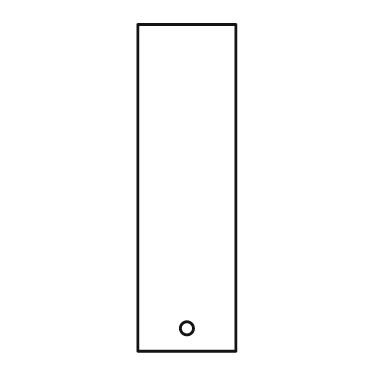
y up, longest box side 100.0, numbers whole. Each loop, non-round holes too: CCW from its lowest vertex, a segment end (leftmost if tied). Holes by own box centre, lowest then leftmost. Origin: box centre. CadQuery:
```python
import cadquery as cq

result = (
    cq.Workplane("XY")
    .moveTo(-15.0, -50.0)
    .lineTo(15.0, -50.0)
    .lineTo(15.0, 50.0)
    .lineTo(-15.0, 50.0)
    .close()
    .moveTo(0.0, -43.0)
    .circle(2.0)
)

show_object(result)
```